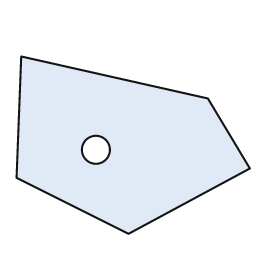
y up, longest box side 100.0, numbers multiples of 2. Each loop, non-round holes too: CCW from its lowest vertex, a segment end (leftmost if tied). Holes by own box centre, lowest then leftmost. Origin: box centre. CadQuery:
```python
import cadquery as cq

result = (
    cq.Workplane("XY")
    .moveTo(-2.0, -38.0)
    .lineTo(50.0, -10.0)
    .lineTo(32.0, 20.0)
    .lineTo(-48.0, 38.0)
    .lineTo(-50.0, -14.0)
    .close()
    .moveTo(-16.0, -2.0)
    .circle(6.0)
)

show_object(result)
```